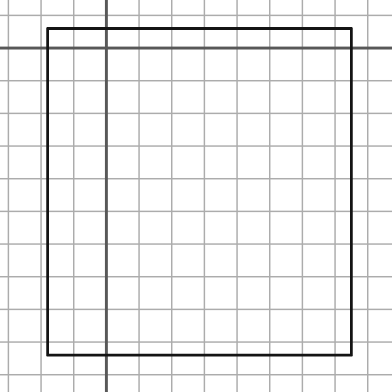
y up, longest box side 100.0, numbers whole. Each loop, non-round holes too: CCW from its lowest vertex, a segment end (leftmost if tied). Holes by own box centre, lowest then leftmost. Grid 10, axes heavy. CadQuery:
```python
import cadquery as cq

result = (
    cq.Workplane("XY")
    .moveTo(-18.0, -94.0)
    .lineTo(75.0, -94.0)
    .lineTo(75.0, 6.0)
    .lineTo(-18.0, 6.0)
    .close()
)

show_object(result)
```